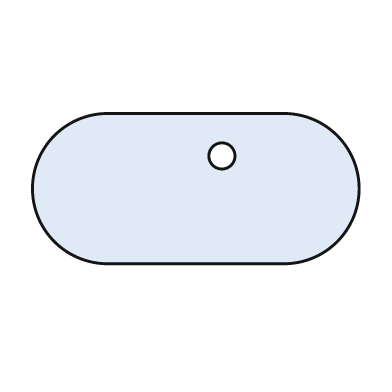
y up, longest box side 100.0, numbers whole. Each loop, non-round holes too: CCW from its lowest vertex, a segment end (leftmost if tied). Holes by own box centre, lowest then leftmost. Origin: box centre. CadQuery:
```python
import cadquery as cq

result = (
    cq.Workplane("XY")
    .moveTo(-27.0, -23.0)
    .lineTo(27.0, -23.0)
    .threePointArc((50.0, 0.0), (27.0, 23.0))
    .lineTo(-27.0, 23.0)
    .threePointArc((-50.0, 0.0), (-27.0, -23.0))
    .close()
    .moveTo(8.0, 10.0)
    .circle(4.0)
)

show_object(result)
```